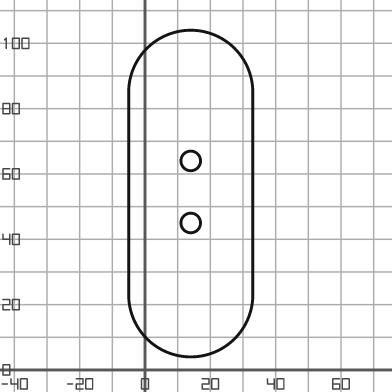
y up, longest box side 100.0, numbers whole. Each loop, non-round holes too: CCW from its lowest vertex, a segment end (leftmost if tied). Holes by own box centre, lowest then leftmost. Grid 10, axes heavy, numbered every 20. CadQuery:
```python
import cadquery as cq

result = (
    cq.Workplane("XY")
    .moveTo(-5.0, 23.0)
    .threePointArc((14.0, 4.0), (33.0, 23.0))
    .lineTo(33.0, 85.0)
    .threePointArc((14.0, 104.0), (-5.0, 85.0))
    .close()
    .moveTo(14.0, 45.0)
    .circle(3.0)
    .moveTo(14.0, 64.0)
    .circle(3.0)
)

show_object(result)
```